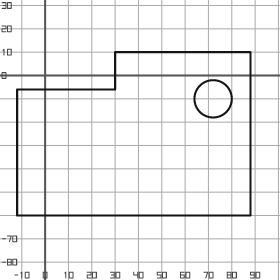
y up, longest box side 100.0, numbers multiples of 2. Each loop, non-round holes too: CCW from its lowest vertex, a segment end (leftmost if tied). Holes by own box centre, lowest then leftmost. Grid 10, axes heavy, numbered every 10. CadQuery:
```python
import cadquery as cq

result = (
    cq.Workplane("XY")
    .moveTo(-12.0, -60.0)
    .lineTo(88.0, -60.0)
    .lineTo(88.0, 10.0)
    .lineTo(30.0, 10.0)
    .lineTo(30.0, -6.0)
    .lineTo(-12.0, -6.0)
    .close()
    .moveTo(72.0, -10.0)
    .circle(8.0)
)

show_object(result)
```